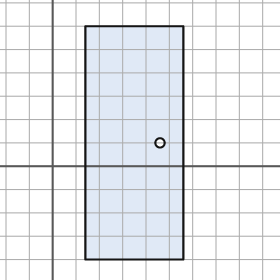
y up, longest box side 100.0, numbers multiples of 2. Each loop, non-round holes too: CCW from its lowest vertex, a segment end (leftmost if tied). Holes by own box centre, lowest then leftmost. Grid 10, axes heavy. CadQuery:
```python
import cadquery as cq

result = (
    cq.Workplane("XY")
    .moveTo(14.0, -40.0)
    .lineTo(56.0, -40.0)
    .lineTo(56.0, 60.0)
    .lineTo(14.0, 60.0)
    .close()
    .moveTo(46.0, 10.0)
    .circle(2.0)
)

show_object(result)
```